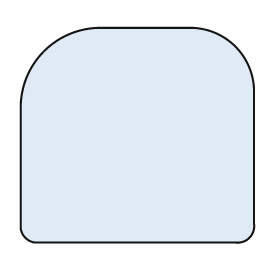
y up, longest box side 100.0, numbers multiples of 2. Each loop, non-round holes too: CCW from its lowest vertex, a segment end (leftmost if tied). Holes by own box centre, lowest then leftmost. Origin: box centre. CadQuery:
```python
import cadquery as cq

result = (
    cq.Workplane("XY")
    .moveTo(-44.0, -46.0)
    .lineTo(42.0, -46.0)
    .threePointArc((48.0, -44.0), (50.0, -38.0))
    .lineTo(50.0, 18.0)
    .threePointArc((42.0, 38.0), (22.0, 46.0))
    .lineTo(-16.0, 46.0)
    .threePointArc((-40.0, 36.0), (-50.0, 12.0))
    .lineTo(-50.0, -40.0)
    .threePointArc((-48.0, -44.0), (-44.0, -46.0))
    .close()
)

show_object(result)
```